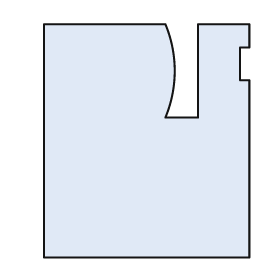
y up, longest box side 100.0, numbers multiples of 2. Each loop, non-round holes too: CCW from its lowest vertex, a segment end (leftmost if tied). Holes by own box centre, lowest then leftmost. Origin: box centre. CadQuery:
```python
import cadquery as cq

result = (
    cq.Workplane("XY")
    .moveTo(-44.0, -50.0)
    .lineTo(44.0, -50.0)
    .lineTo(44.0, 26.0)
    .lineTo(40.0, 26.0)
    .lineTo(40.0, 40.0)
    .lineTo(44.0, 40.0)
    .lineTo(44.0, 50.0)
    .lineTo(22.0, 50.0)
    .lineTo(22.0, 10.0)
    .lineTo(8.0, 10.0)
    .threePointArc((12.0, 30.0), (8.0, 50.0))
    .lineTo(-44.0, 50.0)
    .close()
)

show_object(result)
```